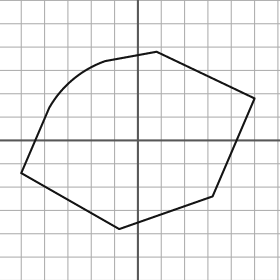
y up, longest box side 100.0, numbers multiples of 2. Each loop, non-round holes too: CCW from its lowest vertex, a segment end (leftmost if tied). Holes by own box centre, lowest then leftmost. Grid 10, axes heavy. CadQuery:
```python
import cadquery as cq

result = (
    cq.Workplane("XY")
    .moveTo(-8.0, -38.0)
    .lineTo(32.0, -24.0)
    .lineTo(50.0, 18.0)
    .lineTo(8.0, 38.0)
    .lineTo(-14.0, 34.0)
    .threePointArc((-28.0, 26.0), (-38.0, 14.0))
    .lineTo(-50.0, -14.0)
    .close()
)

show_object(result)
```